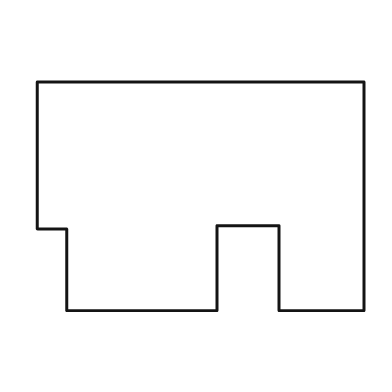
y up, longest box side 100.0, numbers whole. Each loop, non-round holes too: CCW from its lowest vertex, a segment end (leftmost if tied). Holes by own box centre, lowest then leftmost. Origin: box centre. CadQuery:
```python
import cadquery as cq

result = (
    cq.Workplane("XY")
    .moveTo(-41.0, -35.0)
    .lineTo(5.0, -35.0)
    .lineTo(5.0, -9.0)
    .lineTo(24.0, -9.0)
    .lineTo(24.0, -35.0)
    .lineTo(50.0, -35.0)
    .lineTo(50.0, 35.0)
    .lineTo(-50.0, 35.0)
    .lineTo(-50.0, -10.0)
    .lineTo(-41.0, -10.0)
    .close()
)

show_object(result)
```